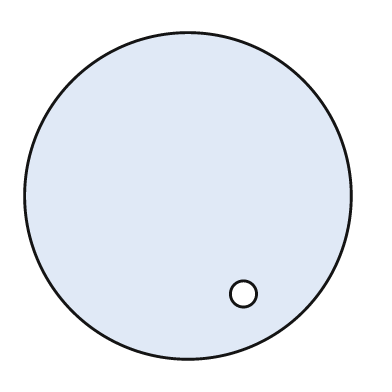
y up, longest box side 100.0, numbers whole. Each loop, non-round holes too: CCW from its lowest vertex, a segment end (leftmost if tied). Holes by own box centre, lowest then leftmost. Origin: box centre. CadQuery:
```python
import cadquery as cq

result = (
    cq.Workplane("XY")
    .moveTo(0.0, 0.0)
    .circle(50.0)
    .moveTo(17.0, -30.0)
    .circle(4.0)
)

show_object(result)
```